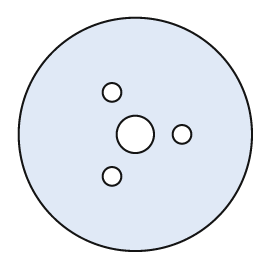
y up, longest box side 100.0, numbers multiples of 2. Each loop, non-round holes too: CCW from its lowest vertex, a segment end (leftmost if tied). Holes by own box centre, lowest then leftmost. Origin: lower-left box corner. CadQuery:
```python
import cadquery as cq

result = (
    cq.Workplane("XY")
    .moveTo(50.0, 50.0)
    .circle(50.0)
    .moveTo(40.0, 32.0)
    .circle(4.0)
    .moveTo(50.0, 50.0)
    .circle(8.0)
    .moveTo(70.0, 50.0)
    .circle(4.0)
    .moveTo(40.0, 68.0)
    .circle(4.0)
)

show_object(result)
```